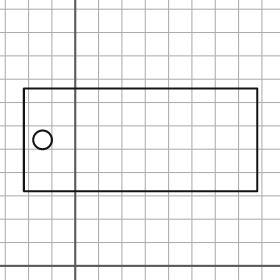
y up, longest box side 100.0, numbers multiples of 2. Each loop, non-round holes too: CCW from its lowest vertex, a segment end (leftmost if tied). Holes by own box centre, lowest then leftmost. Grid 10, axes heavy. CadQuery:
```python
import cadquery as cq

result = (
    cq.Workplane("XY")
    .moveTo(-22.0, 32.0)
    .lineTo(78.0, 32.0)
    .lineTo(78.0, 76.0)
    .lineTo(-22.0, 76.0)
    .close()
    .moveTo(-14.0, 54.0)
    .circle(4.0)
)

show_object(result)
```